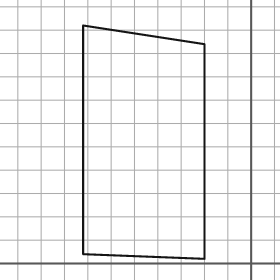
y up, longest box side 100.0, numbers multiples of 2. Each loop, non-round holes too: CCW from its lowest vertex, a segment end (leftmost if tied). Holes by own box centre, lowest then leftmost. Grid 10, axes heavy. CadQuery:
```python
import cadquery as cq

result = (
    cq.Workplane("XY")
    .moveTo(-20.0, 2.0)
    .lineTo(-20.0, 94.0)
    .lineTo(-72.0, 102.0)
    .lineTo(-72.0, 4.0)
    .close()
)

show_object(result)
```